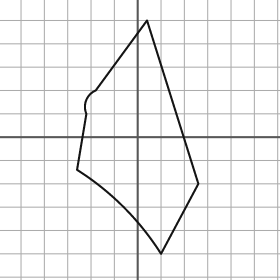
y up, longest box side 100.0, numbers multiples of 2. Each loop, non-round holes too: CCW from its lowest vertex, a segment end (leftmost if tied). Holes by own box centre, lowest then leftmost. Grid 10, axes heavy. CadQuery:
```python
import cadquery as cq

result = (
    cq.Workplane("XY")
    .moveTo(10.0, -50.0)
    .lineTo(26.0, -20.0)
    .lineTo(4.0, 50.0)
    .lineTo(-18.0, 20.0)
    .threePointArc((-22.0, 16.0), (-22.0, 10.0))
    .lineTo(-26.0, -14.0)
    .threePointArc((-6.0, -30.0), (10.0, -50.0))
    .close()
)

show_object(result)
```